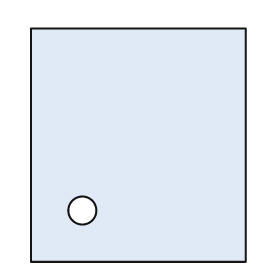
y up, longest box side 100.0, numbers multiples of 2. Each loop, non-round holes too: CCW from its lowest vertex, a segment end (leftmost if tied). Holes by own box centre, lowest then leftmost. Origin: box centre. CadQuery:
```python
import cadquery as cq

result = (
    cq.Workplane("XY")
    .moveTo(-46.0, -50.0)
    .lineTo(46.0, -50.0)
    .lineTo(46.0, 50.0)
    .lineTo(-46.0, 50.0)
    .close()
    .moveTo(-24.0, -28.0)
    .circle(6.0)
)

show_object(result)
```